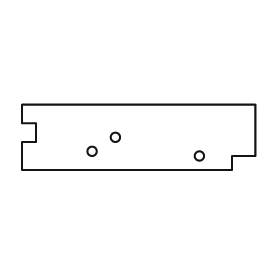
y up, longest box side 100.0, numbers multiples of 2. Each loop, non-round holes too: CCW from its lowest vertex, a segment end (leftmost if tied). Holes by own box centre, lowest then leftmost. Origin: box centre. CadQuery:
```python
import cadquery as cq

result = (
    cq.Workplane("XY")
    .moveTo(-50.0, -14.0)
    .lineTo(40.0, -14.0)
    .lineTo(40.0, -8.0)
    .lineTo(50.0, -8.0)
    .lineTo(50.0, 14.0)
    .lineTo(-50.0, 14.0)
    .lineTo(-50.0, 6.0)
    .lineTo(-44.0, 6.0)
    .lineTo(-44.0, -2.0)
    .lineTo(-50.0, -2.0)
    .close()
    .moveTo(26.0, -8.0)
    .circle(2.0)
    .moveTo(-20.0, -6.0)
    .circle(2.0)
    .moveTo(-10.0, 0.0)
    .circle(2.0)
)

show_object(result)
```